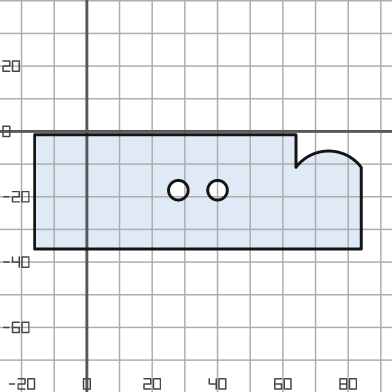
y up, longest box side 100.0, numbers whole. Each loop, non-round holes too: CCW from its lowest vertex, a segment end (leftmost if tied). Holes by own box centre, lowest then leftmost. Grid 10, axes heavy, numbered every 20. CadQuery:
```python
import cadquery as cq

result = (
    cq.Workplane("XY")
    .moveTo(-16.0, -36.0)
    .lineTo(84.0, -36.0)
    .lineTo(84.0, -11.0)
    .threePointArc((74.0, -6.0), (64.0, -11.0))
    .lineTo(64.0, -1.0)
    .lineTo(-16.0, -1.0)
    .close()
    .moveTo(28.0, -18.0)
    .circle(3.0)
    .moveTo(40.0, -18.0)
    .circle(3.0)
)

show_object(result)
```